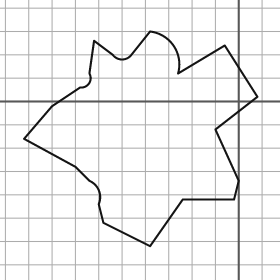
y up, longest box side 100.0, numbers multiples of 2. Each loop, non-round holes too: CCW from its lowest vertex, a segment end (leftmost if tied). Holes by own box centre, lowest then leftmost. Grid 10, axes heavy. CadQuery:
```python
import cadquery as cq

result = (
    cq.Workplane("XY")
    .moveTo(-38.0, -62.0)
    .lineTo(-24.0, -42.0)
    .lineTo(-2.0, -42.0)
    .lineTo(0.0, -34.0)
    .lineTo(-10.0, -12.0)
    .lineTo(8.0, 2.0)
    .lineTo(-6.0, 24.0)
    .lineTo(-26.0, 12.0)
    .threePointArc((-28.0, 24.0), (-38.0, 30.0))
    .lineTo(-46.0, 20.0)
    .threePointArc((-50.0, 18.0), (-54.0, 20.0))
    .lineTo(-62.0, 26.0)
    .lineTo(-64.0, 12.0)
    .threePointArc((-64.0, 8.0), (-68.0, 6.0))
    .lineTo(-80.0, -2.0)
    .lineTo(-92.0, -16.0)
    .lineTo(-70.0, -28.0)
    .lineTo(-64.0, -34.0)
    .threePointArc((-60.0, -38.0), (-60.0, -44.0))
    .lineTo(-58.0, -52.0)
    .close()
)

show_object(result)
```